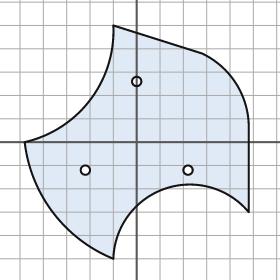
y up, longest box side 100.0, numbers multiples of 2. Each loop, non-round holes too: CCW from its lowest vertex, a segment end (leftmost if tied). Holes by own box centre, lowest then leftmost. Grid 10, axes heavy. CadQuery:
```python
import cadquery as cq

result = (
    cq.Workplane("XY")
    .moveTo(-10.0, -50.0)
    .threePointArc((12.0, -20.0), (48.0, -30.0))
    .lineTo(48.0, 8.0)
    .threePointArc((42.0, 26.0), (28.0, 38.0))
    .lineTo(-10.0, 50.0)
    .threePointArc((-20.0, 18.0), (-48.0, 0.0))
    .threePointArc((-36.0, -30.0), (-10.0, -50.0))
    .close()
    .moveTo(-22.0, -12.0)
    .circle(2.0)
    .moveTo(22.0, -12.0)
    .circle(2.0)
    .moveTo(0.0, 26.0)
    .circle(2.0)
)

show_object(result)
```